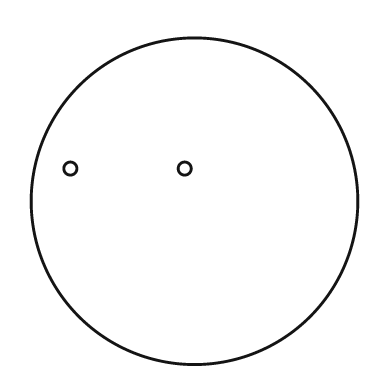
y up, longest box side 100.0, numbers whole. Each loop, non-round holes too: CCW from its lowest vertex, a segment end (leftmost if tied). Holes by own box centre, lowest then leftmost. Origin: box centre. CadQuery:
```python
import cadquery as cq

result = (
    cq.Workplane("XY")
    .moveTo(0.0, 0.0)
    .circle(50.0)
    .moveTo(-38.0, 10.0)
    .circle(2.0)
    .moveTo(-3.0, 10.0)
    .circle(2.0)
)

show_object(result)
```